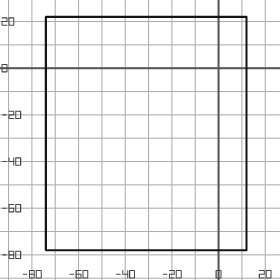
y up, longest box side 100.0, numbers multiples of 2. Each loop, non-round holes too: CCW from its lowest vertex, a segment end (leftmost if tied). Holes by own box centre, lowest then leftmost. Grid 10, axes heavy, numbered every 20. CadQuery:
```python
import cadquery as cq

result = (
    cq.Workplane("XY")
    .moveTo(-74.0, -78.0)
    .lineTo(12.0, -78.0)
    .lineTo(12.0, 22.0)
    .lineTo(-74.0, 22.0)
    .close()
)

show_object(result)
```